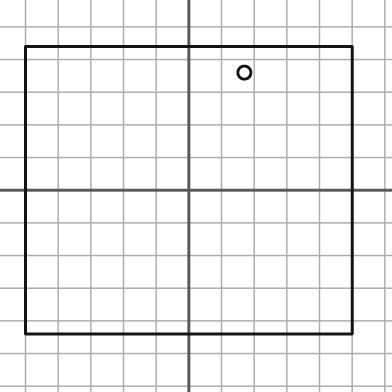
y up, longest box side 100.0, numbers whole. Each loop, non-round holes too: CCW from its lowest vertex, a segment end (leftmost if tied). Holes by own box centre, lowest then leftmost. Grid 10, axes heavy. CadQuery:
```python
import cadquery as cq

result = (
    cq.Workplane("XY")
    .moveTo(-50.0, -44.0)
    .lineTo(50.0, -44.0)
    .lineTo(50.0, 44.0)
    .lineTo(-50.0, 44.0)
    .close()
    .moveTo(17.0, 36.0)
    .circle(2.0)
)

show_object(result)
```